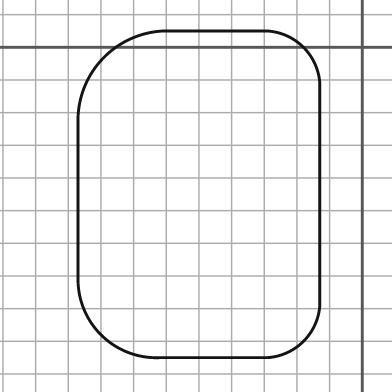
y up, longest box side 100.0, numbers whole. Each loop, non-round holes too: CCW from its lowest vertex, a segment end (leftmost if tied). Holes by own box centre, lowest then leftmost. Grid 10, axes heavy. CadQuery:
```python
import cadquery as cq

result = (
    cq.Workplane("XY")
    .moveTo(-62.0, -95.0)
    .lineTo(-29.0, -95.0)
    .threePointArc((-18.0, -90.0), (-13.0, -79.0))
    .lineTo(-13.0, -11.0)
    .threePointArc((-18.0, 0.0), (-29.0, 5.0))
    .lineTo(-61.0, 5.0)
    .threePointArc((-79.0, -3.0), (-87.0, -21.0))
    .lineTo(-87.0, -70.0)
    .threePointArc((-80.0, -88.0), (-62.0, -95.0))
    .close()
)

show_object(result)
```